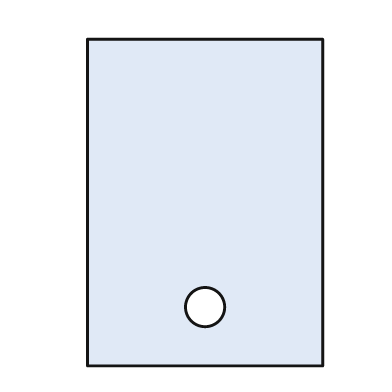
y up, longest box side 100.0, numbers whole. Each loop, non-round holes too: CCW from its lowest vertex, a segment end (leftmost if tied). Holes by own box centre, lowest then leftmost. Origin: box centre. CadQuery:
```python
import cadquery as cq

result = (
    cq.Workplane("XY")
    .moveTo(-36.0, -50.0)
    .lineTo(36.0, -50.0)
    .lineTo(36.0, 50.0)
    .lineTo(-36.0, 50.0)
    .close()
    .moveTo(0.0, -32.0)
    .circle(6.0)
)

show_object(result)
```